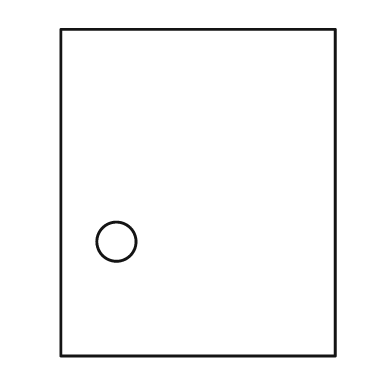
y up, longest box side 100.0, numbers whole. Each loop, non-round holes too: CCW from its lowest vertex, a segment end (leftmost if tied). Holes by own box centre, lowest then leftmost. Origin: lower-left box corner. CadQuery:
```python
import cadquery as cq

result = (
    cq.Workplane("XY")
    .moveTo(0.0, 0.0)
    .lineTo(84.0, 0.0)
    .lineTo(84.0, 100.0)
    .lineTo(0.0, 100.0)
    .close()
    .moveTo(17.0, 35.0)
    .circle(6.0)
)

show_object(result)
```